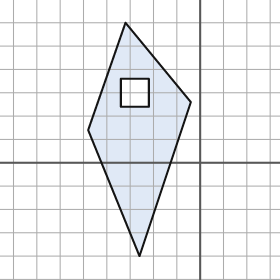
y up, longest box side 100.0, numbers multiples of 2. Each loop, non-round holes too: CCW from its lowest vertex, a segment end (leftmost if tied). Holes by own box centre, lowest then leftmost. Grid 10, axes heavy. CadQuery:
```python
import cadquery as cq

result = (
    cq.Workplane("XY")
    .moveTo(-26.0, -40.0)
    .lineTo(-4.0, 26.0)
    .lineTo(-32.0, 60.0)
    .lineTo(-48.0, 14.0)
    .close()
    .moveTo(-34.0, 24.0)
    .lineTo(-22.0, 24.0)
    .lineTo(-22.0, 36.0)
    .lineTo(-34.0, 36.0)
    .close()
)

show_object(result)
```